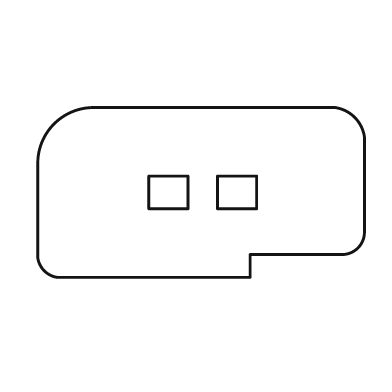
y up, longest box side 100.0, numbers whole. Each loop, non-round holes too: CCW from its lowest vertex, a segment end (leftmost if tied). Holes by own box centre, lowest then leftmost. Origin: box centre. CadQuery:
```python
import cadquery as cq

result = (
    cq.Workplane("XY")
    .moveTo(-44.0, -26.0)
    .lineTo(15.0, -26.0)
    .lineTo(15.0, -19.0)
    .lineTo(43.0, -19.0)
    .threePointArc((48.0, -17.0), (50.0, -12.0))
    .lineTo(50.0, 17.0)
    .threePointArc((47.0, 23.0), (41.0, 26.0))
    .lineTo(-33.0, 26.0)
    .threePointArc((-45.0, 21.0), (-50.0, 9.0))
    .lineTo(-50.0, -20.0)
    .threePointArc((-48.0, -24.0), (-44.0, -26.0))
    .close()
    .moveTo(-16.0, -5.0)
    .lineTo(-4.0, -5.0)
    .lineTo(-4.0, 5.0)
    .lineTo(-16.0, 5.0)
    .close()
    .moveTo(5.0, -5.0)
    .lineTo(17.0, -5.0)
    .lineTo(17.0, 5.0)
    .lineTo(5.0, 5.0)
    .close()
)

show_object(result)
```